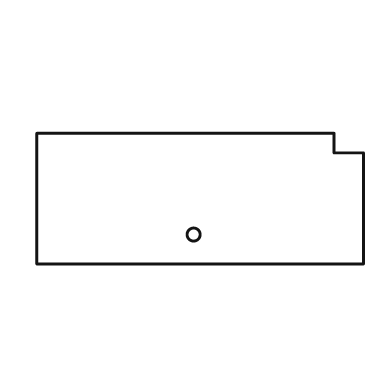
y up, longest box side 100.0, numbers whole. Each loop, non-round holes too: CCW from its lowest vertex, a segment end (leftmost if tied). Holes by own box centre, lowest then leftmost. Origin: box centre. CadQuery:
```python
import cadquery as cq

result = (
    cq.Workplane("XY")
    .moveTo(-50.0, -20.0)
    .lineTo(50.0, -20.0)
    .lineTo(50.0, 14.0)
    .lineTo(41.0, 14.0)
    .lineTo(41.0, 20.0)
    .lineTo(-50.0, 20.0)
    .close()
    .moveTo(-2.0, -11.0)
    .circle(2.0)
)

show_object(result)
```